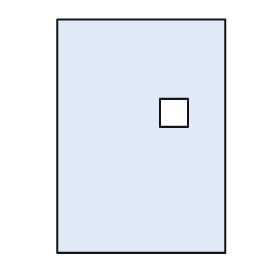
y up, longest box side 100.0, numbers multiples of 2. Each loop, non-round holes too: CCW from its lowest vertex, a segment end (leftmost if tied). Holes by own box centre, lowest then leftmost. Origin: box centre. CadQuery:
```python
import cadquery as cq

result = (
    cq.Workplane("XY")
    .moveTo(-36.0, -50.0)
    .lineTo(36.0, -50.0)
    .lineTo(36.0, 50.0)
    .lineTo(-36.0, 50.0)
    .close()
    .moveTo(8.0, 4.0)
    .lineTo(20.0, 4.0)
    .lineTo(20.0, 16.0)
    .lineTo(8.0, 16.0)
    .close()
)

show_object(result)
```